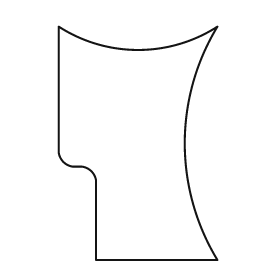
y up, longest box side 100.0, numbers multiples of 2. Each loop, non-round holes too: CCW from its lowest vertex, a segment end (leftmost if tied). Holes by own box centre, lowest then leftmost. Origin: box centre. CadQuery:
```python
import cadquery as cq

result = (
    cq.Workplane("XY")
    .moveTo(-18.0, -50.0)
    .lineTo(34.0, -50.0)
    .threePointArc((20.0, 0.0), (34.0, 50.0))
    .threePointArc((0.0, 40.0), (-34.0, 50.0))
    .lineTo(-34.0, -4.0)
    .threePointArc((-32.0, -8.0), (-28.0, -10.0))
    .lineTo(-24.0, -10.0)
    .threePointArc((-20.0, -12.0), (-18.0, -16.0))
    .close()
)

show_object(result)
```